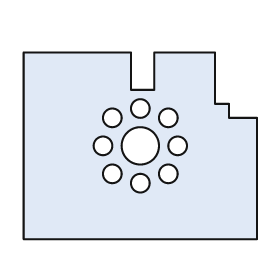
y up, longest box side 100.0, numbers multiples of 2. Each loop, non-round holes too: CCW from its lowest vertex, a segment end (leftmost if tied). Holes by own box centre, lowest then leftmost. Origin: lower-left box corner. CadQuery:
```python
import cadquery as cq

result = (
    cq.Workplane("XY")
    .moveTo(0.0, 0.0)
    .lineTo(100.0, 0.0)
    .lineTo(100.0, 52.0)
    .lineTo(88.0, 52.0)
    .lineTo(88.0, 58.0)
    .lineTo(82.0, 58.0)
    .lineTo(82.0, 80.0)
    .lineTo(56.0, 80.0)
    .lineTo(56.0, 64.0)
    .lineTo(46.0, 64.0)
    .lineTo(46.0, 80.0)
    .lineTo(0.0, 80.0)
    .close()
    .moveTo(50.0, 24.0)
    .circle(4.0)
    .moveTo(38.0, 28.0)
    .circle(4.0)
    .moveTo(62.0, 28.0)
    .circle(4.0)
    .moveTo(34.0, 40.0)
    .circle(4.0)
    .moveTo(50.0, 40.0)
    .circle(8.0)
    .moveTo(66.0, 40.0)
    .circle(4.0)
    .moveTo(38.0, 52.0)
    .circle(4.0)
    .moveTo(62.0, 52.0)
    .circle(4.0)
    .moveTo(50.0, 56.0)
    .circle(4.0)
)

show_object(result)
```